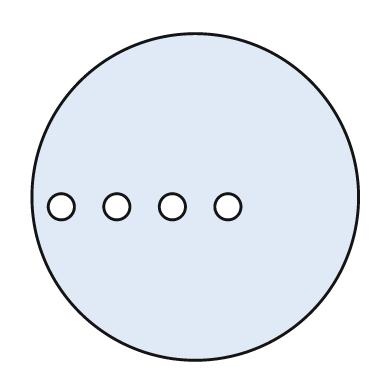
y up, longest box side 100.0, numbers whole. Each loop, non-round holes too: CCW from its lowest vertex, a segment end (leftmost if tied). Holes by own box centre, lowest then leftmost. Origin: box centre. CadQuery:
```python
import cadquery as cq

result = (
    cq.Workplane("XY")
    .moveTo(0.0, 0.0)
    .circle(50.0)
    .moveTo(-41.0, -3.0)
    .circle(4.0)
    .moveTo(-24.0, -3.0)
    .circle(4.0)
    .moveTo(-7.0, -3.0)
    .circle(4.0)
    .moveTo(10.0, -3.0)
    .circle(4.0)
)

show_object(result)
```